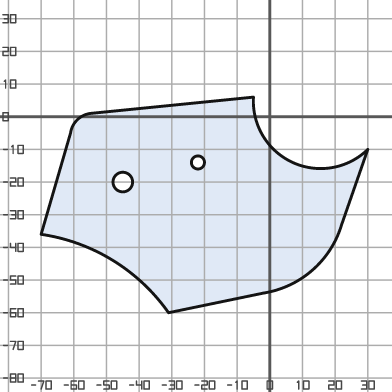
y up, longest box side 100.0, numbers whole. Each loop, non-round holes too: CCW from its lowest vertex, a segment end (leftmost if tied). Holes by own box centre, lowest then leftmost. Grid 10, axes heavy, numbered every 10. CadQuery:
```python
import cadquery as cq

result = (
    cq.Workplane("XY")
    .moveTo(-31.0, -60.0)
    .lineTo(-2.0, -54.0)
    .threePointArc((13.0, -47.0), (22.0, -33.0))
    .lineTo(30.0, -10.0)
    .threePointArc((7.0, -14.0), (-5.0, 6.0))
    .lineTo(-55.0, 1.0)
    .threePointArc((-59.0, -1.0), (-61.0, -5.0))
    .lineTo(-70.0, -36.0)
    .threePointArc((-48.0, -44.0), (-31.0, -60.0))
    .close()
    .moveTo(-45.0, -20.0)
    .circle(3.0)
    .moveTo(-22.0, -14.0)
    .circle(2.0)
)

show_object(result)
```